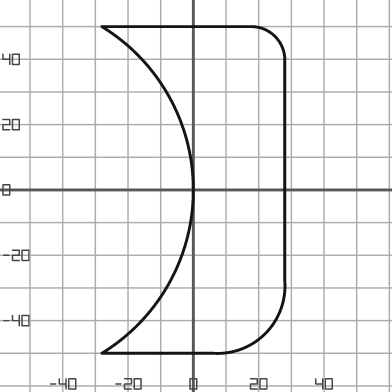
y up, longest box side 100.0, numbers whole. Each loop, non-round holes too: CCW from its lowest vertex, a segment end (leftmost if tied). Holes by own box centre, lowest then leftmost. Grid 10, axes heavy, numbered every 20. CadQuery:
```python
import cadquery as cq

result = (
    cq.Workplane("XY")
    .moveTo(-28.0, -50.0)
    .lineTo(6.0, -50.0)
    .threePointArc((22.0, -44.0), (28.0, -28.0))
    .lineTo(28.0, 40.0)
    .threePointArc((25.0, 47.0), (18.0, 50.0))
    .lineTo(-28.0, 50.0)
    .threePointArc((0.0, 0.0), (-28.0, -50.0))
    .close()
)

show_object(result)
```